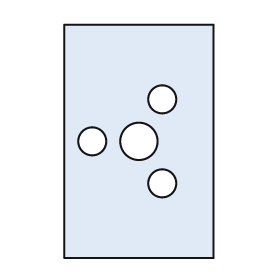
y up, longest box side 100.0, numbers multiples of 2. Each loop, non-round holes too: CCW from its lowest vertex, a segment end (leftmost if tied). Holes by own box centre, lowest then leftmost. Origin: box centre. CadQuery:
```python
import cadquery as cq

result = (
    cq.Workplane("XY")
    .moveTo(-32.0, -50.0)
    .lineTo(32.0, -50.0)
    .lineTo(32.0, 50.0)
    .lineTo(-32.0, 50.0)
    .close()
    .moveTo(10.0, -18.0)
    .circle(6.0)
    .moveTo(-20.0, 0.0)
    .circle(6.0)
    .moveTo(0.0, 0.0)
    .circle(8.0)
    .moveTo(10.0, 18.0)
    .circle(6.0)
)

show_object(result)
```